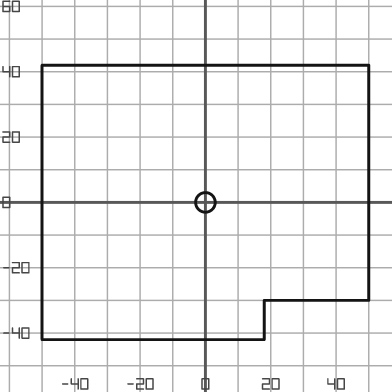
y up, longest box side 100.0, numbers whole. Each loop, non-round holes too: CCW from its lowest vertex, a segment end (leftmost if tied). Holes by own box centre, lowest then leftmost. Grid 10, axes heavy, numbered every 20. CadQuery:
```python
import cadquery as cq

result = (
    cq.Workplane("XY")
    .moveTo(-50.0, -42.0)
    .lineTo(18.0, -42.0)
    .lineTo(18.0, -30.0)
    .lineTo(50.0, -30.0)
    .lineTo(50.0, 42.0)
    .lineTo(-50.0, 42.0)
    .close()
    .moveTo(0.0, 0.0)
    .circle(3.0)
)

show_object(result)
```